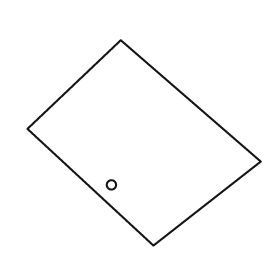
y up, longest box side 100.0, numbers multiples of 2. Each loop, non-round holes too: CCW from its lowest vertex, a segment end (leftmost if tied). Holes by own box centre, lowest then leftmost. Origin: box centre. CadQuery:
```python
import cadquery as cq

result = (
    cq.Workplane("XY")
    .moveTo(4.0, -44.0)
    .lineTo(50.0, -8.0)
    .lineTo(-10.0, 44.0)
    .lineTo(-50.0, 6.0)
    .close()
    .moveTo(-14.0, -18.0)
    .circle(2.0)
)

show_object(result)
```